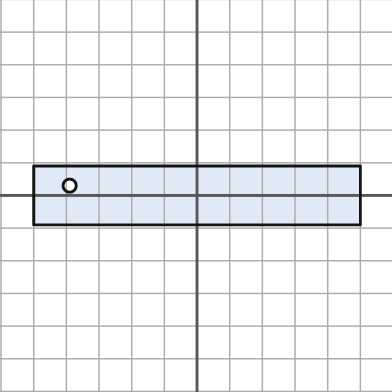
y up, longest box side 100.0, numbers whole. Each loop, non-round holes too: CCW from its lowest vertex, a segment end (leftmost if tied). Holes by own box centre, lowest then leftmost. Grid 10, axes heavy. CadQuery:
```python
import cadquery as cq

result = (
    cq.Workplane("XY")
    .moveTo(-50.0, -9.0)
    .lineTo(50.0, -9.0)
    .lineTo(50.0, 9.0)
    .lineTo(-50.0, 9.0)
    .close()
    .moveTo(-39.0, 3.0)
    .circle(2.0)
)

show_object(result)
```